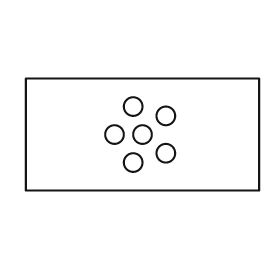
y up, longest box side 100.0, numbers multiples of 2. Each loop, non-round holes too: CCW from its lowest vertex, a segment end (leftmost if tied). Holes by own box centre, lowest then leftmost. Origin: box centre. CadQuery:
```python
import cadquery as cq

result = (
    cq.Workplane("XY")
    .moveTo(-50.0, -24.0)
    .lineTo(50.0, -24.0)
    .lineTo(50.0, 24.0)
    .lineTo(-50.0, 24.0)
    .close()
    .moveTo(-4.0, -12.0)
    .circle(4.0)
    .moveTo(10.0, -8.0)
    .circle(4.0)
    .moveTo(-12.0, 0.0)
    .circle(4.0)
    .moveTo(0.0, 0.0)
    .circle(4.0)
    .moveTo(10.0, 8.0)
    .circle(4.0)
    .moveTo(-4.0, 12.0)
    .circle(4.0)
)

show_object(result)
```